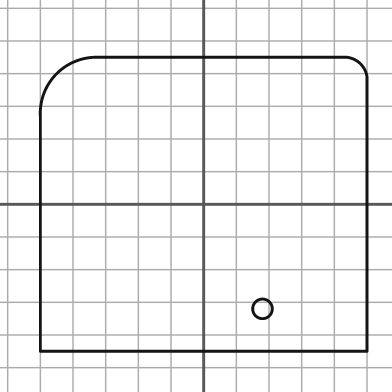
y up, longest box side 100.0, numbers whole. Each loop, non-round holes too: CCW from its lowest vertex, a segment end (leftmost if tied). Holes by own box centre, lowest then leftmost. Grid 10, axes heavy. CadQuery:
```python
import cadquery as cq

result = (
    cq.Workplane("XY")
    .moveTo(-50.0, -45.0)
    .lineTo(50.0, -45.0)
    .lineTo(50.0, 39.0)
    .threePointArc((48.0, 43.0), (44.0, 45.0))
    .lineTo(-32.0, 45.0)
    .threePointArc((-45.0, 40.0), (-50.0, 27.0))
    .close()
    .moveTo(18.0, -32.0)
    .circle(3.0)
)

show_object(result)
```